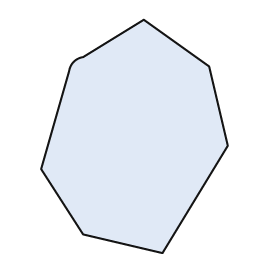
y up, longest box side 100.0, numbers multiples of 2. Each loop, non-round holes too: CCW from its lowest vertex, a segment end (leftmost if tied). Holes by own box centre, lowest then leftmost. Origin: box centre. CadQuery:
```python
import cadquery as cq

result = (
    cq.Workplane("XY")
    .moveTo(12.0, -50.0)
    .lineTo(40.0, -4.0)
    .lineTo(32.0, 30.0)
    .lineTo(4.0, 50.0)
    .lineTo(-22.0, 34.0)
    .threePointArc((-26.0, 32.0), (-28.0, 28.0))
    .lineTo(-40.0, -14.0)
    .lineTo(-22.0, -42.0)
    .close()
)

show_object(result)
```